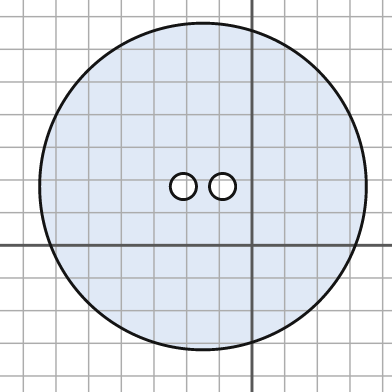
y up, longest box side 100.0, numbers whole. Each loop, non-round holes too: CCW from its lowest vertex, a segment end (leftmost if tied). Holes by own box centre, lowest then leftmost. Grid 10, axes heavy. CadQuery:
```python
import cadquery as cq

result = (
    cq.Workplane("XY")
    .moveTo(-15.0, 18.0)
    .circle(50.0)
    .moveTo(-21.0, 18.0)
    .circle(4.0)
    .moveTo(-9.0, 18.0)
    .circle(4.0)
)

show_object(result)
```